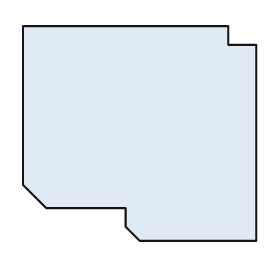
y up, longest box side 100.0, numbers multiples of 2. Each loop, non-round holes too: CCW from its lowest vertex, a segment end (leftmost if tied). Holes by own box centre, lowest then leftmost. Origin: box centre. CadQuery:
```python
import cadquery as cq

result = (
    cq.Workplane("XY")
    .moveTo(0.0, -46.0)
    .lineTo(50.0, -46.0)
    .lineTo(50.0, 38.0)
    .lineTo(38.0, 38.0)
    .lineTo(38.0, 46.0)
    .lineTo(-50.0, 46.0)
    .lineTo(-50.0, -22.0)
    .lineTo(-40.0, -32.0)
    .lineTo(-6.0, -32.0)
    .lineTo(-6.0, -40.0)
    .close()
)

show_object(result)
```